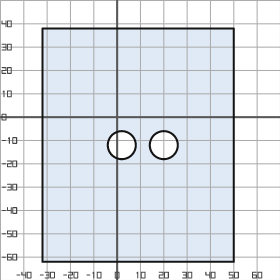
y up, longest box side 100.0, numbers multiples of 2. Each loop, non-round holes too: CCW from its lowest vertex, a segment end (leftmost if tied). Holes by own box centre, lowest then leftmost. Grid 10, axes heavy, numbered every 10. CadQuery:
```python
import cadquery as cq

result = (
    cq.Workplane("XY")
    .moveTo(-32.0, -62.0)
    .lineTo(50.0, -62.0)
    .lineTo(50.0, 38.0)
    .lineTo(-32.0, 38.0)
    .close()
    .moveTo(2.0, -12.0)
    .circle(6.0)
    .moveTo(20.0, -12.0)
    .circle(6.0)
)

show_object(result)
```